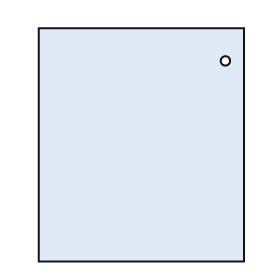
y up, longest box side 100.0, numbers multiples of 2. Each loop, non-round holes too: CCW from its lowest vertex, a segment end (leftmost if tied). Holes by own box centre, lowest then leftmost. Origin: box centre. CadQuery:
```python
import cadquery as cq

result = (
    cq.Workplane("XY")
    .moveTo(-44.0, -50.0)
    .lineTo(44.0, -50.0)
    .lineTo(44.0, 50.0)
    .lineTo(-44.0, 50.0)
    .close()
    .moveTo(36.0, 36.0)
    .circle(2.0)
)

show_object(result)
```